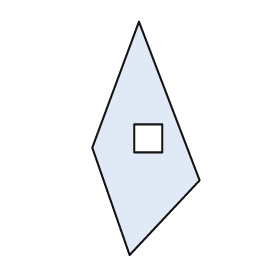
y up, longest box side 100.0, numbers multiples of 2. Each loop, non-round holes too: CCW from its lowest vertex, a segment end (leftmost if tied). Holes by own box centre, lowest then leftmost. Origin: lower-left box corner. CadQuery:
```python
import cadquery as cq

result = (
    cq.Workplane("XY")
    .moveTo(16.0, 0.0)
    .lineTo(46.0, 32.0)
    .lineTo(20.0, 100.0)
    .lineTo(0.0, 46.0)
    .close()
    .moveTo(18.0, 44.0)
    .lineTo(30.0, 44.0)
    .lineTo(30.0, 56.0)
    .lineTo(18.0, 56.0)
    .close()
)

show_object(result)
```